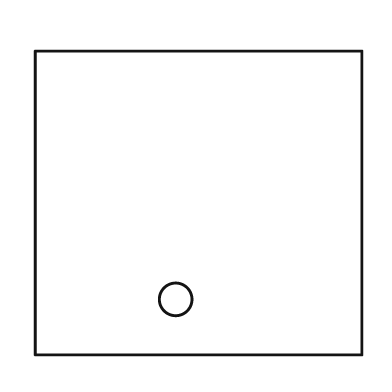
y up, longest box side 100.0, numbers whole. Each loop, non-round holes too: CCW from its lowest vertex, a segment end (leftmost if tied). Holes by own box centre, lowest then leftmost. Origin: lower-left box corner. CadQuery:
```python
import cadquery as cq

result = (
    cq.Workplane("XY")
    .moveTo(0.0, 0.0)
    .lineTo(100.0, 0.0)
    .lineTo(100.0, 93.0)
    .lineTo(0.0, 93.0)
    .close()
    .moveTo(43.0, 17.0)
    .circle(5.0)
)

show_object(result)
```